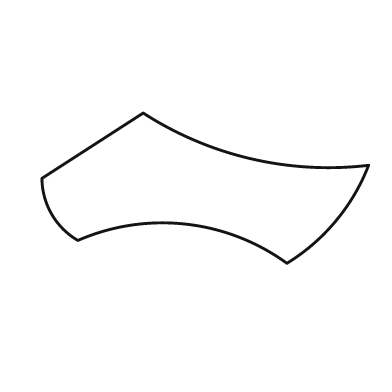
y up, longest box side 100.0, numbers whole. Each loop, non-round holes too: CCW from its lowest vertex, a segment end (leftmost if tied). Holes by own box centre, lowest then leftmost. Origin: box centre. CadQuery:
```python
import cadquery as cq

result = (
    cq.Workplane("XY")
    .moveTo(25.0, -23.0)
    .threePointArc((40.0, -10.0), (50.0, 7.0))
    .threePointArc((14.0, 9.0), (-19.0, 23.0))
    .lineTo(-50.0, 3.0)
    .threePointArc((-47.0, -8.0), (-39.0, -16.0))
    .threePointArc((-6.0, -11.0), (25.0, -23.0))
    .close()
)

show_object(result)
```